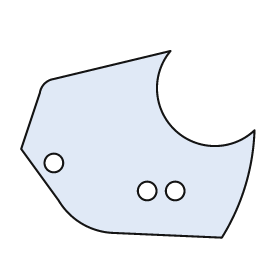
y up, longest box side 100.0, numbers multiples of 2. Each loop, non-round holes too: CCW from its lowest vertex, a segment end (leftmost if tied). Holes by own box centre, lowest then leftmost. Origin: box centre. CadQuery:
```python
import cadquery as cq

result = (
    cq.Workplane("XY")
    .moveTo(36.0, -40.0)
    .threePointArc((46.0, -18.0), (50.0, 6.0))
    .threePointArc((16.0, 6.0), (14.0, 40.0))
    .lineTo(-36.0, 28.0)
    .threePointArc((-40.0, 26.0), (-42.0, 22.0))
    .lineTo(-50.0, -2.0)
    .lineTo(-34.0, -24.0)
    .threePointArc((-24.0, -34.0), (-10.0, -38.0))
    .close()
    .moveTo(4.0, -20.0)
    .circle(4.0)
    .moveTo(16.0, -20.0)
    .circle(4.0)
    .moveTo(-36.0, -8.0)
    .circle(4.0)
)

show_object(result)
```